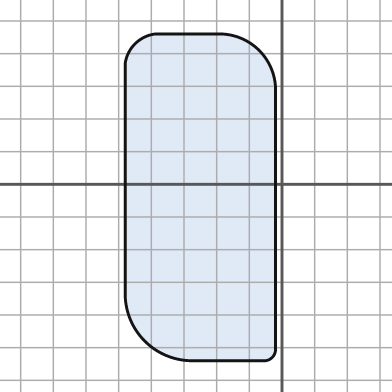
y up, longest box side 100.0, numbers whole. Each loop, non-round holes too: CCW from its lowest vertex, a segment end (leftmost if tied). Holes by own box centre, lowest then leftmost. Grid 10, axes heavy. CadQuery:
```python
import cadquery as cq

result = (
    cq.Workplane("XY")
    .moveTo(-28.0, -54.0)
    .lineTo(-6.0, -54.0)
    .threePointArc((-3.0, -53.0), (-2.0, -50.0))
    .lineTo(-2.0, 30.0)
    .threePointArc((-7.0, 41.0), (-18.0, 46.0))
    .lineTo(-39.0, 46.0)
    .threePointArc((-45.0, 43.0), (-48.0, 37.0))
    .lineTo(-48.0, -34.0)
    .threePointArc((-42.0, -48.0), (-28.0, -54.0))
    .close()
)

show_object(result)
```